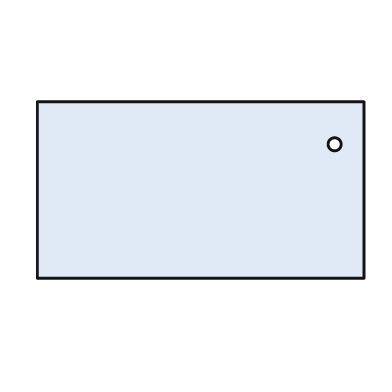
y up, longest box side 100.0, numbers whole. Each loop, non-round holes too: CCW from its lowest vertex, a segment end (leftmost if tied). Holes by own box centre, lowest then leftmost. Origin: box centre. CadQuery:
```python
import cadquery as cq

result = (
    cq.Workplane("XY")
    .moveTo(-50.0, -27.0)
    .lineTo(50.0, -27.0)
    .lineTo(50.0, 27.0)
    .lineTo(-50.0, 27.0)
    .close()
    .moveTo(41.0, 14.0)
    .circle(2.0)
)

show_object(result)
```